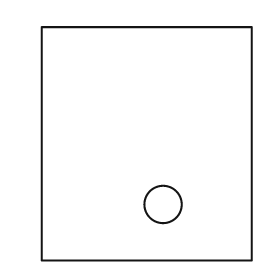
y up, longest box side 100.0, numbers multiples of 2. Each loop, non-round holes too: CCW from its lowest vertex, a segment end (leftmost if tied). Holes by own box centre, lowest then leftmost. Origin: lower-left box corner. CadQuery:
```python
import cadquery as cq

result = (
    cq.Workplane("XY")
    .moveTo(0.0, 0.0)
    .lineTo(90.0, 0.0)
    .lineTo(90.0, 100.0)
    .lineTo(0.0, 100.0)
    .close()
    .moveTo(52.0, 24.0)
    .circle(8.0)
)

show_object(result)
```